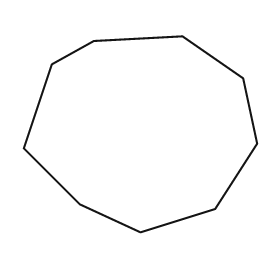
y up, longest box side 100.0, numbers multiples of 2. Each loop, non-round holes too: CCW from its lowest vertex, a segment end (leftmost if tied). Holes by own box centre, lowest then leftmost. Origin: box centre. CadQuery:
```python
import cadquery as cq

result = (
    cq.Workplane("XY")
    .moveTo(0.0, -42.0)
    .lineTo(32.0, -32.0)
    .lineTo(50.0, -4.0)
    .lineTo(44.0, 24.0)
    .lineTo(18.0, 42.0)
    .lineTo(-20.0, 40.0)
    .lineTo(-38.0, 30.0)
    .lineTo(-50.0, -6.0)
    .lineTo(-26.0, -30.0)
    .close()
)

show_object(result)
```